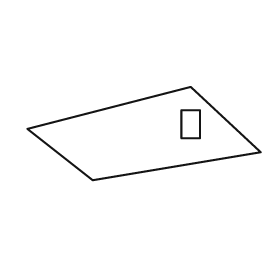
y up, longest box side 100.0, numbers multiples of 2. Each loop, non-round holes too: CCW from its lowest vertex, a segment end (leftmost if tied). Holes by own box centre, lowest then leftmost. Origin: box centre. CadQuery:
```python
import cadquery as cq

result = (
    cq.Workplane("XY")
    .moveTo(-22.0, -20.0)
    .lineTo(50.0, -8.0)
    .lineTo(20.0, 20.0)
    .lineTo(-50.0, 2.0)
    .close()
    .moveTo(16.0, -2.0)
    .lineTo(24.0, -2.0)
    .lineTo(24.0, 10.0)
    .lineTo(16.0, 10.0)
    .close()
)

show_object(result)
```